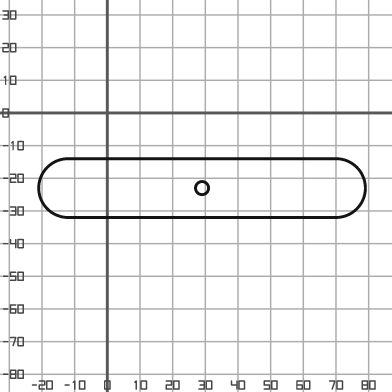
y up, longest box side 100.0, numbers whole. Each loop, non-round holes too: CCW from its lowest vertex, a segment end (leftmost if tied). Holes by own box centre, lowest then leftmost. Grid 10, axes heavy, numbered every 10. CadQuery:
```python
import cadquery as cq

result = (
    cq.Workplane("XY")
    .moveTo(-12.0, -32.0)
    .lineTo(70.0, -32.0)
    .threePointArc((79.0, -23.0), (70.0, -14.0))
    .lineTo(-12.0, -14.0)
    .threePointArc((-21.0, -23.0), (-12.0, -32.0))
    .close()
    .moveTo(29.0, -23.0)
    .circle(2.0)
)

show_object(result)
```